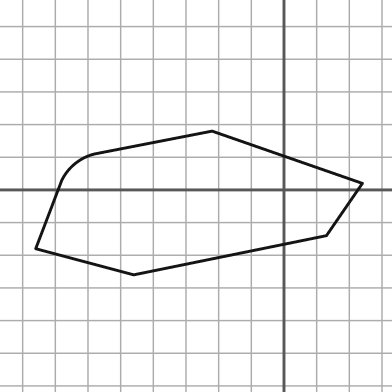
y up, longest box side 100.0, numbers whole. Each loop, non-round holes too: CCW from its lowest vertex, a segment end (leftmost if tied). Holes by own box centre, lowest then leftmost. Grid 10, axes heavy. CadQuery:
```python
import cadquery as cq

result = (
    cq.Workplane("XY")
    .moveTo(-46.0, -26.0)
    .lineTo(13.0, -14.0)
    .lineTo(24.0, 2.0)
    .lineTo(-22.0, 18.0)
    .lineTo(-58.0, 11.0)
    .threePointArc((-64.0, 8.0), (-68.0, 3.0))
    .lineTo(-76.0, -18.0)
    .close()
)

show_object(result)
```